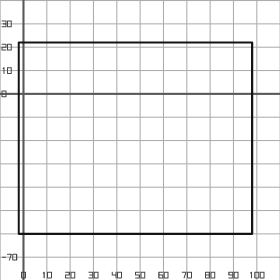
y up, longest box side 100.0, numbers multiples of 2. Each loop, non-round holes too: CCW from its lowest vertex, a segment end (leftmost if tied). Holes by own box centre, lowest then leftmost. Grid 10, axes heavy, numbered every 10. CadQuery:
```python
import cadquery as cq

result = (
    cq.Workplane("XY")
    .moveTo(-2.0, -60.0)
    .lineTo(98.0, -60.0)
    .lineTo(98.0, 22.0)
    .lineTo(-2.0, 22.0)
    .close()
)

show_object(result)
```